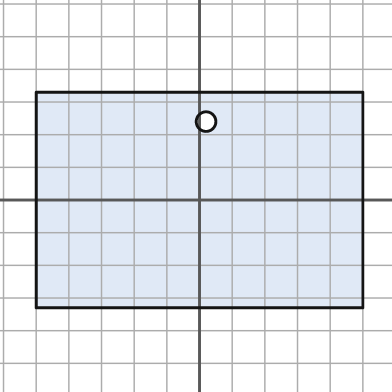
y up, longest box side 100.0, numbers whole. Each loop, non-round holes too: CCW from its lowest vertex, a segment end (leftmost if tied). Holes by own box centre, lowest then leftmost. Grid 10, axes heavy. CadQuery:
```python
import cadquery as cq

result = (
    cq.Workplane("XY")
    .moveTo(-50.0, -33.0)
    .lineTo(50.0, -33.0)
    .lineTo(50.0, 33.0)
    .lineTo(-50.0, 33.0)
    .close()
    .moveTo(2.0, 24.0)
    .circle(3.0)
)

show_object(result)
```